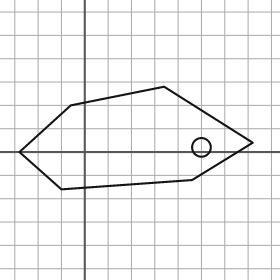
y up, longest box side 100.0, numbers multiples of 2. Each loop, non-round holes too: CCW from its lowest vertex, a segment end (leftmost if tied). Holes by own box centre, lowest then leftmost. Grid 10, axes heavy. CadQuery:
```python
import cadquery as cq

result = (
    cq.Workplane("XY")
    .moveTo(-10.0, -16.0)
    .lineTo(46.0, -12.0)
    .lineTo(72.0, 4.0)
    .lineTo(34.0, 28.0)
    .lineTo(-6.0, 20.0)
    .lineTo(-28.0, 0.0)
    .close()
    .moveTo(50.0, 2.0)
    .circle(4.0)
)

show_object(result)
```